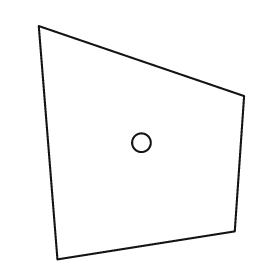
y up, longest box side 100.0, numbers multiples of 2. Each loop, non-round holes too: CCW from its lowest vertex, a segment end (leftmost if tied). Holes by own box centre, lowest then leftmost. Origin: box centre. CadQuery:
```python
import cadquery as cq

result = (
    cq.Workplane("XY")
    .moveTo(-36.0, -50.0)
    .lineTo(40.0, -38.0)
    .lineTo(44.0, 20.0)
    .lineTo(-44.0, 50.0)
    .close()
    .moveTo(0.0, 0.0)
    .circle(4.0)
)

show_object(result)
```